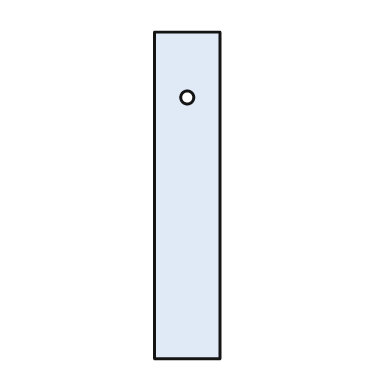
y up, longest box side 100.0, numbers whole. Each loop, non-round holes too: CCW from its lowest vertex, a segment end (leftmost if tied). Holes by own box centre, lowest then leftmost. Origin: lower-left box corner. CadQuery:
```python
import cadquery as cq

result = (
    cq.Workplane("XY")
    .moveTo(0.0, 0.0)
    .lineTo(20.0, 0.0)
    .lineTo(20.0, 100.0)
    .lineTo(0.0, 100.0)
    .close()
    .moveTo(10.0, 80.0)
    .circle(2.0)
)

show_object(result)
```